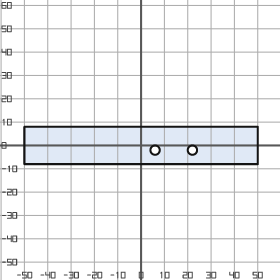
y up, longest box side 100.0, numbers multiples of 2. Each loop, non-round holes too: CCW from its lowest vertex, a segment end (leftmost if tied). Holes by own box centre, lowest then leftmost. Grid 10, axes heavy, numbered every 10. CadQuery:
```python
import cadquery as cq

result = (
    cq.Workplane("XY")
    .moveTo(-50.0, -8.0)
    .lineTo(50.0, -8.0)
    .lineTo(50.0, 8.0)
    .lineTo(-50.0, 8.0)
    .close()
    .moveTo(6.0, -2.0)
    .circle(2.0)
    .moveTo(22.0, -2.0)
    .circle(2.0)
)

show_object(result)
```